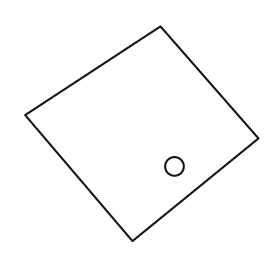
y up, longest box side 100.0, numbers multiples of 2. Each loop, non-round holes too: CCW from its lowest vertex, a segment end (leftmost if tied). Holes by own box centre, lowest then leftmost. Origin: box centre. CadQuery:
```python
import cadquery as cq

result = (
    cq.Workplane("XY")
    .moveTo(-4.0, -46.0)
    .lineTo(50.0, -2.0)
    .lineTo(8.0, 46.0)
    .lineTo(-50.0, 8.0)
    .close()
    .moveTo(14.0, -14.0)
    .circle(4.0)
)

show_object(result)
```